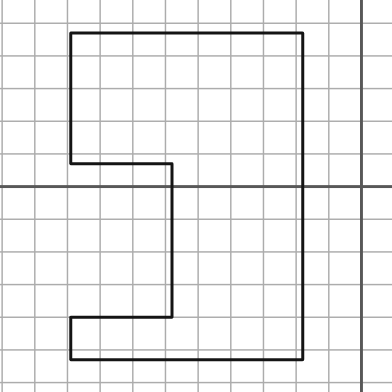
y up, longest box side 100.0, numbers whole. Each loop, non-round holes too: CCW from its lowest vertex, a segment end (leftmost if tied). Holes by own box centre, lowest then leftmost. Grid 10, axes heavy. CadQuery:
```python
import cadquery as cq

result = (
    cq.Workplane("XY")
    .moveTo(-89.0, -53.0)
    .lineTo(-18.0, -53.0)
    .lineTo(-18.0, 47.0)
    .lineTo(-89.0, 47.0)
    .lineTo(-89.0, 7.0)
    .lineTo(-58.0, 7.0)
    .lineTo(-58.0, -40.0)
    .lineTo(-89.0, -40.0)
    .close()
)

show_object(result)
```